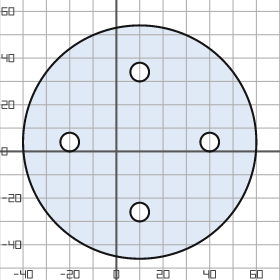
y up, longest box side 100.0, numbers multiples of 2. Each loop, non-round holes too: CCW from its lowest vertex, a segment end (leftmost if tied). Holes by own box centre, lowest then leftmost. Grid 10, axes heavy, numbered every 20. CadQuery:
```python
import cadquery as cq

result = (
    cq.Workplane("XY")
    .moveTo(10.0, 4.0)
    .circle(50.0)
    .moveTo(10.0, -26.0)
    .circle(4.0)
    .moveTo(-20.0, 4.0)
    .circle(4.0)
    .moveTo(40.0, 4.0)
    .circle(4.0)
    .moveTo(10.0, 34.0)
    .circle(4.0)
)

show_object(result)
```